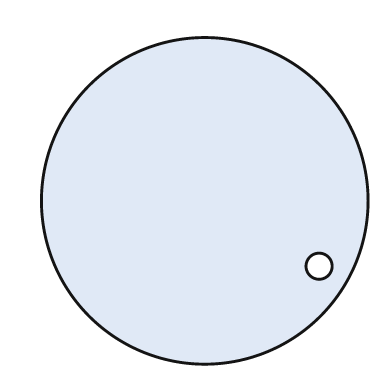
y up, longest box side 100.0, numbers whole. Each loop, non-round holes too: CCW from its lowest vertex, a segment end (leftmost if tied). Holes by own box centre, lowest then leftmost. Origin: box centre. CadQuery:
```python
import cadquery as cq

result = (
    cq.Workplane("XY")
    .moveTo(0.0, 0.0)
    .circle(50.0)
    .moveTo(35.0, -20.0)
    .circle(4.0)
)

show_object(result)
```